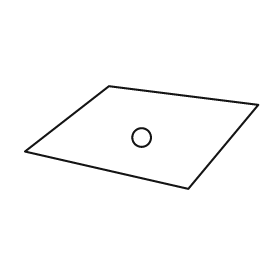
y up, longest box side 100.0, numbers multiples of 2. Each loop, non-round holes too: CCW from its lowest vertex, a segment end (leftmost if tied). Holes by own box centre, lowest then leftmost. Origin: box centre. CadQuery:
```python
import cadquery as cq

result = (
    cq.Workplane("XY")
    .moveTo(20.0, -22.0)
    .lineTo(50.0, 14.0)
    .lineTo(-14.0, 22.0)
    .lineTo(-50.0, -6.0)
    .close()
    .moveTo(0.0, 0.0)
    .circle(4.0)
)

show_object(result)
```